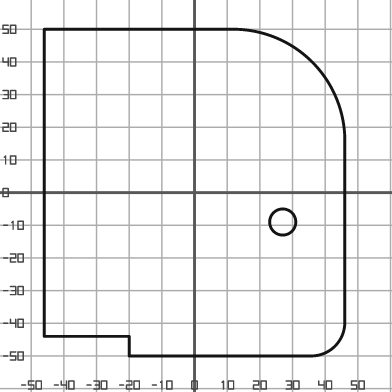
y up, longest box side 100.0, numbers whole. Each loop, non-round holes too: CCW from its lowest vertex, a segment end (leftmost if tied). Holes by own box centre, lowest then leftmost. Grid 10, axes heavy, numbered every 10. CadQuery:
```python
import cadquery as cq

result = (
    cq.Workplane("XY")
    .moveTo(-20.0, -50.0)
    .lineTo(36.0, -50.0)
    .threePointArc((43.0, -47.0), (46.0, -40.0))
    .lineTo(46.0, 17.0)
    .threePointArc((36.0, 40.0), (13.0, 50.0))
    .lineTo(-46.0, 50.0)
    .lineTo(-46.0, -44.0)
    .lineTo(-20.0, -44.0)
    .close()
    .moveTo(27.0, -9.0)
    .circle(4.0)
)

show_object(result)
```